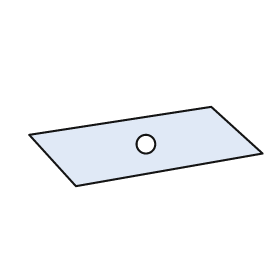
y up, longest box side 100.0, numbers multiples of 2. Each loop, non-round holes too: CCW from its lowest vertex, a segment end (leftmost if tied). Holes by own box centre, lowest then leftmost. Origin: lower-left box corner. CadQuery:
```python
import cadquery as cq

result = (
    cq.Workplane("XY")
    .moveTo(20.0, 0.0)
    .lineTo(100.0, 14.0)
    .lineTo(78.0, 34.0)
    .lineTo(0.0, 22.0)
    .close()
    .moveTo(50.0, 18.0)
    .circle(4.0)
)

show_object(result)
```